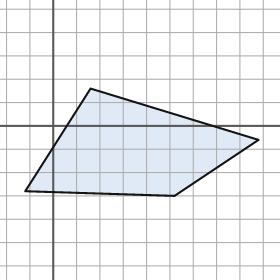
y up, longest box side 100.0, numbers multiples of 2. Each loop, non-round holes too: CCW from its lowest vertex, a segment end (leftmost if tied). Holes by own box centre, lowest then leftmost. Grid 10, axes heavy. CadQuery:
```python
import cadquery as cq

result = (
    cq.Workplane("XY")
    .moveTo(52.0, -30.0)
    .lineTo(88.0, -6.0)
    .lineTo(16.0, 16.0)
    .lineTo(-12.0, -28.0)
    .close()
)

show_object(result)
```